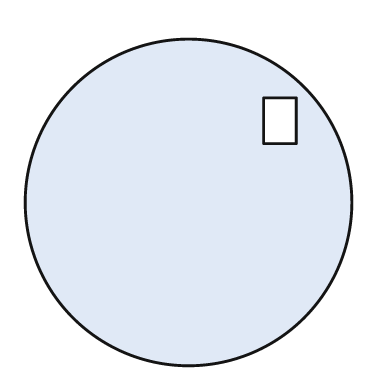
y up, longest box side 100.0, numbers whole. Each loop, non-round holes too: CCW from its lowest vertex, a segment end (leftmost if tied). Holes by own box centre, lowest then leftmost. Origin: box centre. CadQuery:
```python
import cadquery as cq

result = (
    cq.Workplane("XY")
    .moveTo(0.0, 0.0)
    .circle(50.0)
    .moveTo(23.0, 18.0)
    .lineTo(33.0, 18.0)
    .lineTo(33.0, 32.0)
    .lineTo(23.0, 32.0)
    .close()
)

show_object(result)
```